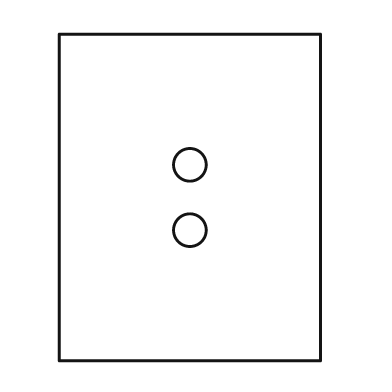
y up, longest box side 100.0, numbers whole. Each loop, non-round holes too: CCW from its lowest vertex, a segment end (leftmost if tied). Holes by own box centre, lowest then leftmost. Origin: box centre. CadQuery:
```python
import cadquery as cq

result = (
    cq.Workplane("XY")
    .moveTo(-40.0, -50.0)
    .lineTo(40.0, -50.0)
    .lineTo(40.0, 50.0)
    .lineTo(-40.0, 50.0)
    .close()
    .moveTo(0.0, -10.0)
    .circle(5.0)
    .moveTo(0.0, 10.0)
    .circle(5.0)
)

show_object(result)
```